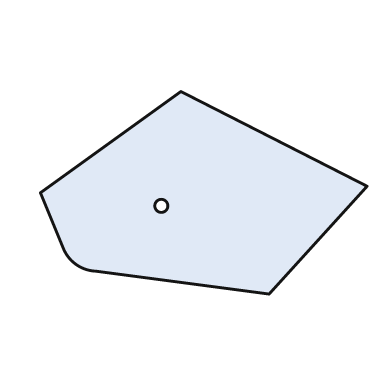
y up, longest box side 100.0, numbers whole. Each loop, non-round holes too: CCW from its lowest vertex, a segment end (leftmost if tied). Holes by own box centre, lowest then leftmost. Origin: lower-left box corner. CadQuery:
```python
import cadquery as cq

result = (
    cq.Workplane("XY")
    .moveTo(70.0, 0.0)
    .lineTo(100.0, 33.0)
    .lineTo(43.0, 62.0)
    .lineTo(0.0, 31.0)
    .lineTo(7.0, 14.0)
    .threePointArc((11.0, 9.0), (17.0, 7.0))
    .close()
    .moveTo(37.0, 27.0)
    .circle(2.0)
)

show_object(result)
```